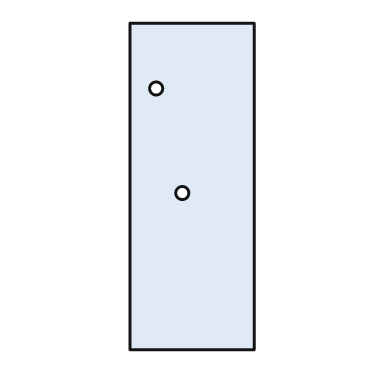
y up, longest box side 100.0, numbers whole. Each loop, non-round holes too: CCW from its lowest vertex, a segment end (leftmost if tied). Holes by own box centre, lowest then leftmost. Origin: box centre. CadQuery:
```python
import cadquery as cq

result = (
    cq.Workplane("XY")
    .moveTo(-19.0, -50.0)
    .lineTo(19.0, -50.0)
    .lineTo(19.0, 50.0)
    .lineTo(-19.0, 50.0)
    .close()
    .moveTo(-3.0, -2.0)
    .circle(2.0)
    .moveTo(-11.0, 30.0)
    .circle(2.0)
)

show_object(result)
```